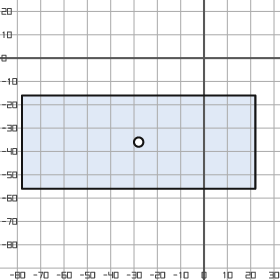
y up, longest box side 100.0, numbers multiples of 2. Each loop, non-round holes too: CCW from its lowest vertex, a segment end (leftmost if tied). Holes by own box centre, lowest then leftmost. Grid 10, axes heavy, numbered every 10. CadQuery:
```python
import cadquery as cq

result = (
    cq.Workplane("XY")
    .moveTo(-78.0, -56.0)
    .lineTo(22.0, -56.0)
    .lineTo(22.0, -16.0)
    .lineTo(-78.0, -16.0)
    .close()
    .moveTo(-28.0, -36.0)
    .circle(2.0)
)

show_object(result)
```